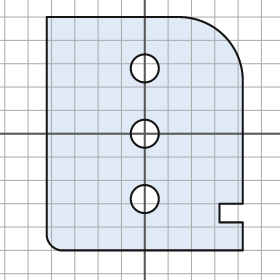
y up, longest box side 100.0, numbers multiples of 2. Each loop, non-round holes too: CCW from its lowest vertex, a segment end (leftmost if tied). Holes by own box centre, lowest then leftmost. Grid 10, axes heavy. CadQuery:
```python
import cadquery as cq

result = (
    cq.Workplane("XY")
    .moveTo(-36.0, -50.0)
    .lineTo(42.0, -50.0)
    .lineTo(42.0, -38.0)
    .lineTo(32.0, -38.0)
    .lineTo(32.0, -30.0)
    .lineTo(42.0, -30.0)
    .lineTo(42.0, 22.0)
    .threePointArc((34.0, 42.0), (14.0, 50.0))
    .lineTo(-42.0, 50.0)
    .lineTo(-42.0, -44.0)
    .threePointArc((-40.0, -48.0), (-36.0, -50.0))
    .close()
    .moveTo(0.0, -28.0)
    .circle(6.0)
    .moveTo(0.0, 0.0)
    .circle(6.0)
    .moveTo(0.0, 28.0)
    .circle(6.0)
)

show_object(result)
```